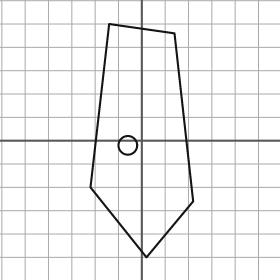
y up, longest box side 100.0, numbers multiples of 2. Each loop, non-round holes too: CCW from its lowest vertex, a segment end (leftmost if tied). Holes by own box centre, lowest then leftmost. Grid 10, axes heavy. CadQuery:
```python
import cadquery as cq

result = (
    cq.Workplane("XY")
    .moveTo(2.0, -50.0)
    .lineTo(22.0, -26.0)
    .lineTo(14.0, 46.0)
    .lineTo(-14.0, 50.0)
    .lineTo(-22.0, -20.0)
    .close()
    .moveTo(-6.0, -2.0)
    .circle(4.0)
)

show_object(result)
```